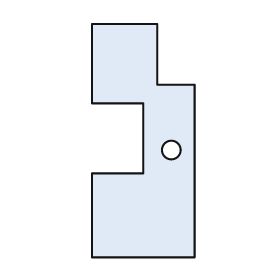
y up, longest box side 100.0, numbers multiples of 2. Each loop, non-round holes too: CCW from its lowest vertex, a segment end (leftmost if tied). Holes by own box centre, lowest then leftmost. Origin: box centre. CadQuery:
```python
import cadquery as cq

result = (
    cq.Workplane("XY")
    .moveTo(-22.0, -50.0)
    .lineTo(22.0, -50.0)
    .lineTo(22.0, 24.0)
    .lineTo(6.0, 24.0)
    .lineTo(6.0, 50.0)
    .lineTo(-22.0, 50.0)
    .lineTo(-22.0, 16.0)
    .lineTo(0.0, 16.0)
    .lineTo(0.0, -14.0)
    .lineTo(-22.0, -14.0)
    .close()
    .moveTo(12.0, -4.0)
    .circle(4.0)
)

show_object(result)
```